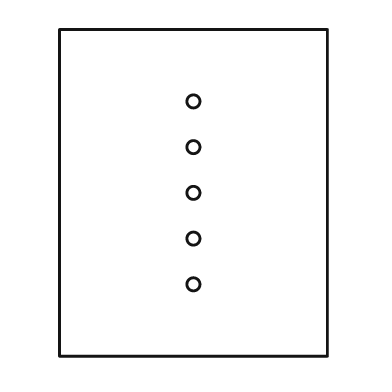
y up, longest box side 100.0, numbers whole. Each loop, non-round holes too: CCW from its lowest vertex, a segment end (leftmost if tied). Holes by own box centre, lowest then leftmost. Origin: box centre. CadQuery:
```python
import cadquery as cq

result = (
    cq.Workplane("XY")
    .moveTo(-41.0, -50.0)
    .lineTo(41.0, -50.0)
    .lineTo(41.0, 50.0)
    .lineTo(-41.0, 50.0)
    .close()
    .moveTo(0.0, -28.0)
    .circle(2.0)
    .moveTo(0.0, -14.0)
    .circle(2.0)
    .moveTo(0.0, 0.0)
    .circle(2.0)
    .moveTo(0.0, 14.0)
    .circle(2.0)
    .moveTo(0.0, 28.0)
    .circle(2.0)
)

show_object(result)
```